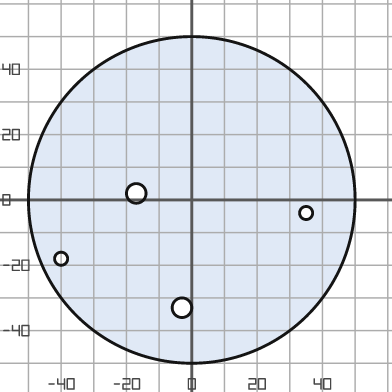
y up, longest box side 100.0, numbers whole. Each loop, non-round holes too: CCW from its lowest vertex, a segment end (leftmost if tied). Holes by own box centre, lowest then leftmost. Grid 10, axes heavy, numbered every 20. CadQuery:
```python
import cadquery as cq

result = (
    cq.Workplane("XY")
    .moveTo(0.0, 0.0)
    .circle(50.0)
    .moveTo(-3.0, -33.0)
    .circle(3.0)
    .moveTo(-40.0, -18.0)
    .circle(2.0)
    .moveTo(35.0, -4.0)
    .circle(2.0)
    .moveTo(-17.0, 2.0)
    .circle(3.0)
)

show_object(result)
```